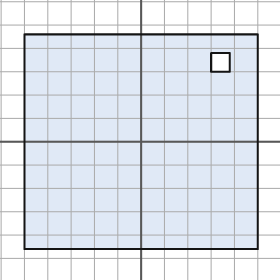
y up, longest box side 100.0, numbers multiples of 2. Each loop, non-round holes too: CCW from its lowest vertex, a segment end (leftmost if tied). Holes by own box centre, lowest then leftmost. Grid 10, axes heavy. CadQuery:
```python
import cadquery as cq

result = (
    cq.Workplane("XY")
    .moveTo(-50.0, -46.0)
    .lineTo(50.0, -46.0)
    .lineTo(50.0, 46.0)
    .lineTo(-50.0, 46.0)
    .close()
    .moveTo(30.0, 30.0)
    .lineTo(38.0, 30.0)
    .lineTo(38.0, 38.0)
    .lineTo(30.0, 38.0)
    .close()
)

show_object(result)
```